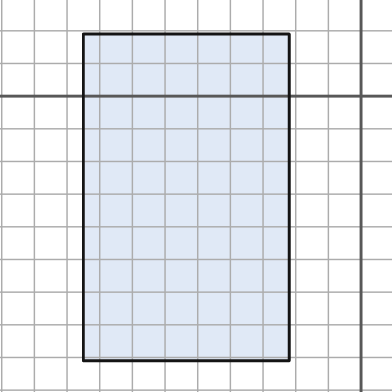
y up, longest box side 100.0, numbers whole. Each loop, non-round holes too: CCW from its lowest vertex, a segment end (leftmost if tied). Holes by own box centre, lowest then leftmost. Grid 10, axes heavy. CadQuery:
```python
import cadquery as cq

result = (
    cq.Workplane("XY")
    .moveTo(-85.0, -81.0)
    .lineTo(-22.0, -81.0)
    .lineTo(-22.0, 19.0)
    .lineTo(-85.0, 19.0)
    .close()
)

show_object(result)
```